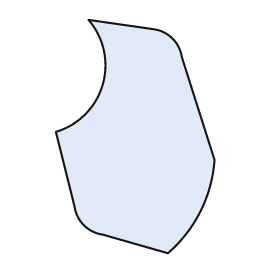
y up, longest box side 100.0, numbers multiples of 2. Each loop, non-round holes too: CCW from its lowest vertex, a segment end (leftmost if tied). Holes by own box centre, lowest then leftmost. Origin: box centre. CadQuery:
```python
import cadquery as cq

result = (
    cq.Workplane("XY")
    .moveTo(14.0, -50.0)
    .threePointArc((28.0, -32.0), (34.0, -10.0))
    .lineTo(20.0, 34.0)
    .threePointArc((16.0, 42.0), (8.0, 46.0))
    .lineTo(-20.0, 50.0)
    .threePointArc((-14.0, 22.0), (-34.0, 2.0))
    .lineTo(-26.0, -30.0)
    .threePointArc((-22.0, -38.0), (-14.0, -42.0))
    .close()
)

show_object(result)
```